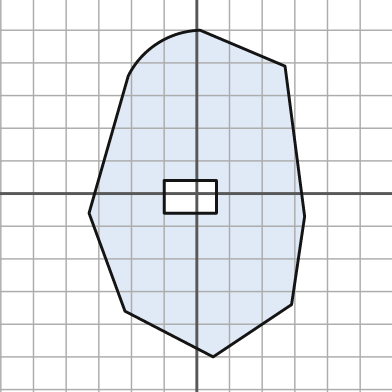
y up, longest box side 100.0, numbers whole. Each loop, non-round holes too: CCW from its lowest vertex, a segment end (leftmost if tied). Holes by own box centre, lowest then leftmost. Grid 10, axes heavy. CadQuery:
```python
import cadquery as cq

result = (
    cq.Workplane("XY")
    .moveTo(5.0, -50.0)
    .lineTo(29.0, -34.0)
    .lineTo(33.0, -7.0)
    .lineTo(27.0, 39.0)
    .lineTo(1.0, 50.0)
    .threePointArc((-12.0, 46.0), (-21.0, 36.0))
    .lineTo(-33.0, -6.0)
    .lineTo(-22.0, -36.0)
    .close()
    .moveTo(-10.0, -6.0)
    .lineTo(6.0, -6.0)
    .lineTo(6.0, 4.0)
    .lineTo(-10.0, 4.0)
    .close()
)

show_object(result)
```